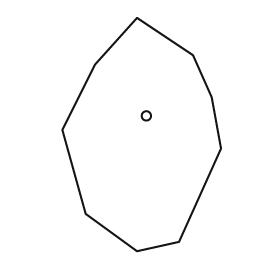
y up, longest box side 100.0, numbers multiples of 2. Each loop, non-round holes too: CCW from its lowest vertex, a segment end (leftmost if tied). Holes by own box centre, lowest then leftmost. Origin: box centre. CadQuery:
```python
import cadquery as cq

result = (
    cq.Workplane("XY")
    .moveTo(-2.0, -50.0)
    .lineTo(16.0, -46.0)
    .lineTo(34.0, -6.0)
    .lineTo(30.0, 16.0)
    .lineTo(22.0, 34.0)
    .lineTo(-2.0, 50.0)
    .lineTo(-20.0, 30.0)
    .lineTo(-34.0, 2.0)
    .lineTo(-24.0, -34.0)
    .close()
    .moveTo(2.0, 8.0)
    .circle(2.0)
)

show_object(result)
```